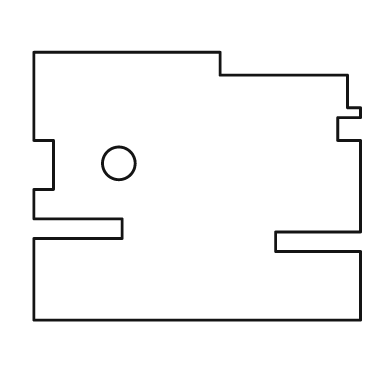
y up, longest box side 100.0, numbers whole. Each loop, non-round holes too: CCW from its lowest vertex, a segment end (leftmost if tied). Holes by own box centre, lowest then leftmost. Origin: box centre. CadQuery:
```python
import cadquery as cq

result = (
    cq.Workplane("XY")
    .moveTo(-50.0, -41.0)
    .lineTo(50.0, -41.0)
    .lineTo(50.0, -20.0)
    .lineTo(24.0, -20.0)
    .lineTo(24.0, -14.0)
    .lineTo(50.0, -14.0)
    .lineTo(50.0, 14.0)
    .lineTo(43.0, 14.0)
    .lineTo(43.0, 21.0)
    .lineTo(50.0, 21.0)
    .lineTo(50.0, 24.0)
    .lineTo(46.0, 24.0)
    .lineTo(46.0, 34.0)
    .lineTo(7.0, 34.0)
    .lineTo(7.0, 41.0)
    .lineTo(-50.0, 41.0)
    .lineTo(-50.0, 14.0)
    .lineTo(-44.0, 14.0)
    .lineTo(-44.0, -1.0)
    .lineTo(-50.0, -1.0)
    .lineTo(-50.0, -10.0)
    .lineTo(-23.0, -10.0)
    .lineTo(-23.0, -16.0)
    .lineTo(-50.0, -16.0)
    .close()
    .moveTo(-24.0, 7.0)
    .circle(5.0)
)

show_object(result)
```